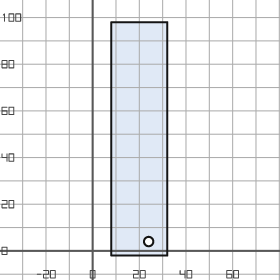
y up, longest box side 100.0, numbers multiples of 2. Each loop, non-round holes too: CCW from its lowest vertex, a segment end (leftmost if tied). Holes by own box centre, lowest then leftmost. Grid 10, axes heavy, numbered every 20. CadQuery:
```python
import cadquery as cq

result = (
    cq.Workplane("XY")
    .moveTo(8.0, -2.0)
    .lineTo(32.0, -2.0)
    .lineTo(32.0, 98.0)
    .lineTo(8.0, 98.0)
    .close()
    .moveTo(24.0, 4.0)
    .circle(2.0)
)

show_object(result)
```